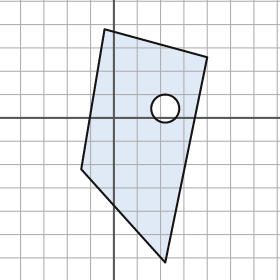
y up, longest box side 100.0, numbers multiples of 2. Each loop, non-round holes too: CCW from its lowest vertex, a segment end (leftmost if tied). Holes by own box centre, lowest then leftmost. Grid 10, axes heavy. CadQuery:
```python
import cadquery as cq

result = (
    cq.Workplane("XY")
    .moveTo(22.0, -62.0)
    .lineTo(40.0, 26.0)
    .lineTo(-4.0, 38.0)
    .lineTo(-14.0, -22.0)
    .close()
    .moveTo(22.0, 4.0)
    .circle(6.0)
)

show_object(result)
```